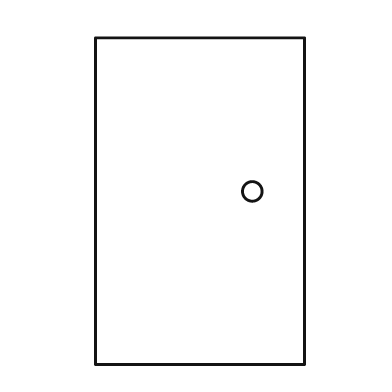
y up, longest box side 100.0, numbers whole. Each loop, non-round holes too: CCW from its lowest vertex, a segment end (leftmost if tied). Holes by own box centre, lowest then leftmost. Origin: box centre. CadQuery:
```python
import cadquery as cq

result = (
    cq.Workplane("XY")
    .moveTo(-32.0, -50.0)
    .lineTo(32.0, -50.0)
    .lineTo(32.0, 50.0)
    .lineTo(-32.0, 50.0)
    .close()
    .moveTo(16.0, 3.0)
    .circle(3.0)
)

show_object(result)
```